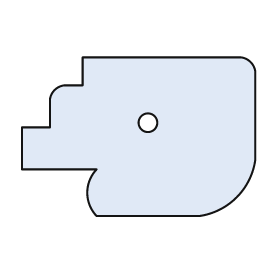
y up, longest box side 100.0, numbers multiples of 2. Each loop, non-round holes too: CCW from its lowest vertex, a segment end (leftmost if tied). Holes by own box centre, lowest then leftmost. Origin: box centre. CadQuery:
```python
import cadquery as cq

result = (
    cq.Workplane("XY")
    .moveTo(-18.0, -34.0)
    .lineTo(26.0, -34.0)
    .threePointArc((42.0, -26.0), (50.0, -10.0))
    .lineTo(50.0, 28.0)
    .threePointArc((48.0, 32.0), (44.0, 34.0))
    .lineTo(-24.0, 34.0)
    .lineTo(-24.0, 22.0)
    .lineTo(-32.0, 22.0)
    .threePointArc((-36.0, 20.0), (-38.0, 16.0))
    .lineTo(-38.0, 4.0)
    .lineTo(-50.0, 4.0)
    .lineTo(-50.0, -14.0)
    .lineTo(-18.0, -14.0)
    .threePointArc((-22.0, -24.0), (-18.0, -34.0))
    .close()
    .moveTo(4.0, 6.0)
    .circle(4.0)
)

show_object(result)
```